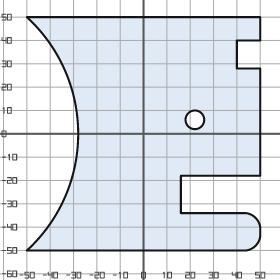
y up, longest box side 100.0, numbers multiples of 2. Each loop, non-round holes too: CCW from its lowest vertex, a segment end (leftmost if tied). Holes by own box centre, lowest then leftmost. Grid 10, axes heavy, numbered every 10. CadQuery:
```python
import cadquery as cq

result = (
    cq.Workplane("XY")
    .moveTo(-50.0, -50.0)
    .lineTo(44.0, -50.0)
    .threePointArc((48.0, -48.0), (50.0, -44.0))
    .lineTo(50.0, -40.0)
    .threePointArc((48.0, -36.0), (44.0, -34.0))
    .lineTo(16.0, -34.0)
    .lineTo(16.0, -18.0)
    .lineTo(50.0, -18.0)
    .lineTo(50.0, 28.0)
    .lineTo(40.0, 28.0)
    .lineTo(40.0, 40.0)
    .lineTo(50.0, 40.0)
    .lineTo(50.0, 50.0)
    .lineTo(-50.0, 50.0)
    .threePointArc((-28.0, 0.0), (-50.0, -50.0))
    .close()
    .moveTo(22.0, 6.0)
    .circle(4.0)
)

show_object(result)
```